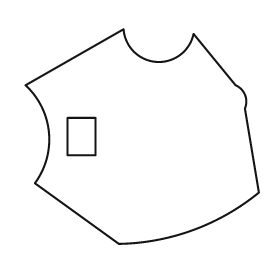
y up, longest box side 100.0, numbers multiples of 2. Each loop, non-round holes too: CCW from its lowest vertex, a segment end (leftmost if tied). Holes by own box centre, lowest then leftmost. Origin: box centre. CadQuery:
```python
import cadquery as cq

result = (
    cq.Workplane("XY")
    .moveTo(-10.0, -46.0)
    .threePointArc((22.0, -40.0), (50.0, -24.0))
    .lineTo(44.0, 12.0)
    .threePointArc((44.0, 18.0), (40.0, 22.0))
    .lineTo(22.0, 44.0)
    .threePointArc((6.0, 32.0), (-8.0, 46.0))
    .lineTo(-50.0, 22.0)
    .threePointArc((-40.0, 2.0), (-46.0, -20.0))
    .close()
    .moveTo(-32.0, -8.0)
    .lineTo(-20.0, -8.0)
    .lineTo(-20.0, 8.0)
    .lineTo(-32.0, 8.0)
    .close()
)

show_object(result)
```